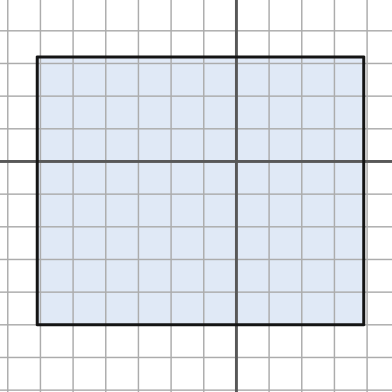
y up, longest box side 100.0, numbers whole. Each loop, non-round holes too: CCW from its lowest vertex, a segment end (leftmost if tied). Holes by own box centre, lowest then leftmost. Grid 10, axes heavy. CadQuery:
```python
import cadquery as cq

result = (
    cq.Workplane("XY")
    .moveTo(-61.0, -50.0)
    .lineTo(39.0, -50.0)
    .lineTo(39.0, 32.0)
    .lineTo(-61.0, 32.0)
    .close()
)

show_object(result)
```